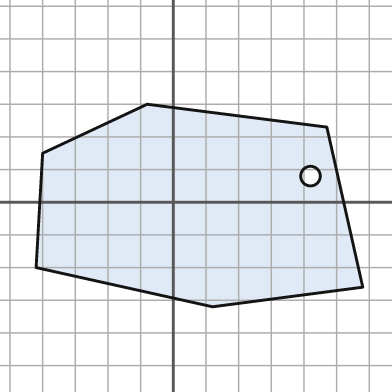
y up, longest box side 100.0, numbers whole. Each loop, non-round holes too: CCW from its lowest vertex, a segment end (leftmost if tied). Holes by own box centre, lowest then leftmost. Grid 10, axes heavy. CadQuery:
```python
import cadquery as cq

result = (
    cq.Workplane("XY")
    .moveTo(12.0, -32.0)
    .lineTo(58.0, -26.0)
    .lineTo(47.0, 23.0)
    .lineTo(-8.0, 30.0)
    .lineTo(-40.0, 15.0)
    .lineTo(-42.0, -20.0)
    .close()
    .moveTo(42.0, 8.0)
    .circle(3.0)
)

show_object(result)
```